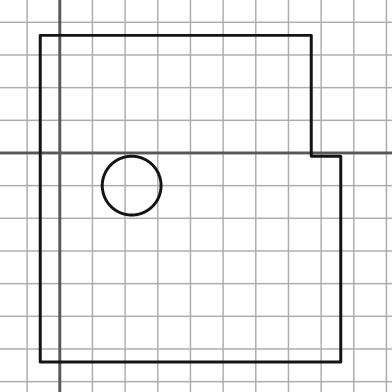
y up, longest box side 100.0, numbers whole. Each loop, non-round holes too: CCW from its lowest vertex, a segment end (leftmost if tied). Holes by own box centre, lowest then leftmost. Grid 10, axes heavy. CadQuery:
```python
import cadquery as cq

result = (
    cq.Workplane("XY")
    .moveTo(-6.0, -64.0)
    .lineTo(86.0, -64.0)
    .lineTo(86.0, -1.0)
    .lineTo(77.0, -1.0)
    .lineTo(77.0, 36.0)
    .lineTo(-6.0, 36.0)
    .close()
    .moveTo(22.0, -10.0)
    .circle(9.0)
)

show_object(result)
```